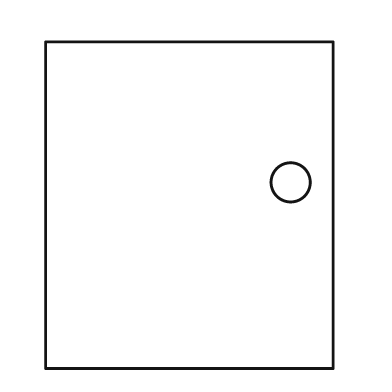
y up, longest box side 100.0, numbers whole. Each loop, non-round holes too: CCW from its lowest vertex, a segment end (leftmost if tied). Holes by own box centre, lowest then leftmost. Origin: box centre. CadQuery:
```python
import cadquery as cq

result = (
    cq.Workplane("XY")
    .moveTo(-44.0, -50.0)
    .lineTo(44.0, -50.0)
    .lineTo(44.0, 50.0)
    .lineTo(-44.0, 50.0)
    .close()
    .moveTo(31.0, 7.0)
    .circle(6.0)
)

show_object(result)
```